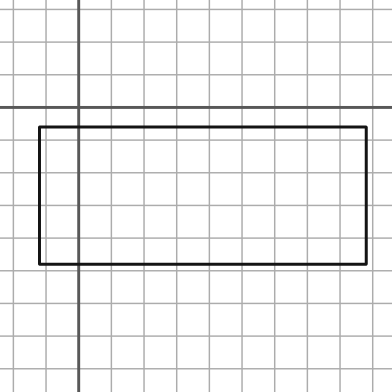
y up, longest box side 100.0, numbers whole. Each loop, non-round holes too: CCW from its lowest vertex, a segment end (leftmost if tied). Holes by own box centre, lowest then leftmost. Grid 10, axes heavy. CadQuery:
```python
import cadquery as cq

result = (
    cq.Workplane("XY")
    .moveTo(-12.0, -48.0)
    .lineTo(88.0, -48.0)
    .lineTo(88.0, -6.0)
    .lineTo(-12.0, -6.0)
    .close()
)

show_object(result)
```